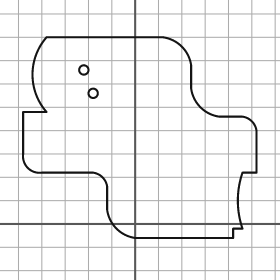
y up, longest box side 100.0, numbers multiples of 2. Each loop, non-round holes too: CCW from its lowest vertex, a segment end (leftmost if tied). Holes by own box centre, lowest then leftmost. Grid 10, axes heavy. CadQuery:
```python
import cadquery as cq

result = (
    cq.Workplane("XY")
    .moveTo(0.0, -6.0)
    .lineTo(42.0, -6.0)
    .lineTo(42.0, -2.0)
    .lineTo(46.0, -2.0)
    .threePointArc((44.0, 10.0), (46.0, 22.0))
    .lineTo(52.0, 22.0)
    .lineTo(52.0, 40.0)
    .threePointArc((50.0, 44.0), (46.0, 46.0))
    .lineTo(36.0, 46.0)
    .threePointArc((28.0, 50.0), (24.0, 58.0))
    .lineTo(24.0, 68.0)
    .threePointArc((20.0, 76.0), (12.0, 80.0))
    .lineTo(-38.0, 80.0)
    .threePointArc((-44.0, 64.0), (-38.0, 48.0))
    .lineTo(-48.0, 48.0)
    .lineTo(-48.0, 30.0)
    .threePointArc((-46.0, 24.0), (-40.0, 22.0))
    .lineTo(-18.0, 22.0)
    .threePointArc((-14.0, 20.0), (-12.0, 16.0))
    .lineTo(-12.0, 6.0)
    .threePointArc((-8.0, -2.0), (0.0, -6.0))
    .close()
    .moveTo(-18.0, 56.0)
    .circle(2.0)
    .moveTo(-22.0, 66.0)
    .circle(2.0)
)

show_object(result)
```